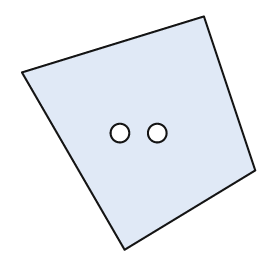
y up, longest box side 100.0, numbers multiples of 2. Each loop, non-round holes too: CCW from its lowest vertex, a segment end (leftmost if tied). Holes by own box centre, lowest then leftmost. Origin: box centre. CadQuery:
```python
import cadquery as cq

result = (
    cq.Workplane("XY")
    .moveTo(-6.0, -50.0)
    .lineTo(50.0, -16.0)
    .lineTo(28.0, 50.0)
    .lineTo(-50.0, 26.0)
    .close()
    .moveTo(-8.0, 0.0)
    .circle(4.0)
    .moveTo(8.0, 0.0)
    .circle(4.0)
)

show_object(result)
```